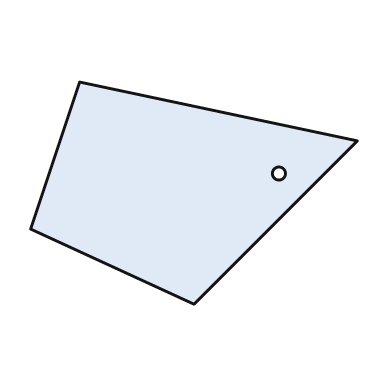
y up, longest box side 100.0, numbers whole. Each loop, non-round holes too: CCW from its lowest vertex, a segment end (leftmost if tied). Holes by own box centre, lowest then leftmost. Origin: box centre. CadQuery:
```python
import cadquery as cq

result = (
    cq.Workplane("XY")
    .moveTo(0.0, -34.0)
    .lineTo(50.0, 16.0)
    .lineTo(-35.0, 34.0)
    .lineTo(-50.0, -11.0)
    .close()
    .moveTo(26.0, 6.0)
    .circle(2.0)
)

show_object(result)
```